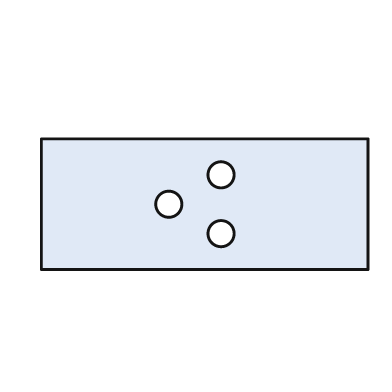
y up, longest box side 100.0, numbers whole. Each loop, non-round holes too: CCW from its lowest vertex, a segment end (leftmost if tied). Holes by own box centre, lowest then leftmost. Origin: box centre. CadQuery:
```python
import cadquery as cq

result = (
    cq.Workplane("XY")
    .moveTo(-50.0, -20.0)
    .lineTo(50.0, -20.0)
    .lineTo(50.0, 20.0)
    .lineTo(-50.0, 20.0)
    .close()
    .moveTo(5.0, -9.0)
    .circle(4.0)
    .moveTo(-11.0, 0.0)
    .circle(4.0)
    .moveTo(5.0, 9.0)
    .circle(4.0)
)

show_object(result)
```